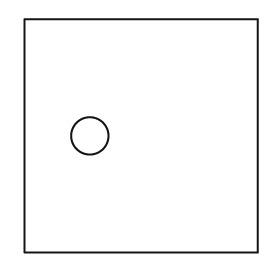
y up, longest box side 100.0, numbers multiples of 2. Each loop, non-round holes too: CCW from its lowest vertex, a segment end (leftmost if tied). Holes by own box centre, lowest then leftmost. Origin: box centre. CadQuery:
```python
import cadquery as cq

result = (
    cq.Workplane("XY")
    .moveTo(-50.0, -50.0)
    .lineTo(50.0, -50.0)
    .lineTo(50.0, 50.0)
    .lineTo(-50.0, 50.0)
    .close()
    .moveTo(-22.0, 0.0)
    .circle(8.0)
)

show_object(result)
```